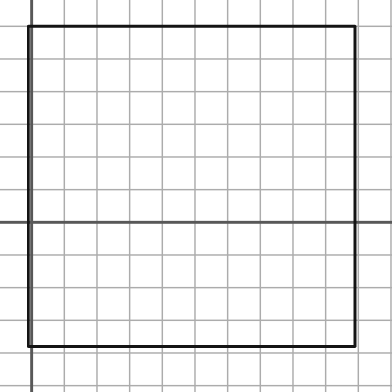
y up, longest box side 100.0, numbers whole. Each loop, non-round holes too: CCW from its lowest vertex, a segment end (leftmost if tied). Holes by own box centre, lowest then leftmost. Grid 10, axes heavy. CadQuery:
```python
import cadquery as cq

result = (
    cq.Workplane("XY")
    .moveTo(-1.0, -38.0)
    .lineTo(99.0, -38.0)
    .lineTo(99.0, 60.0)
    .lineTo(-1.0, 60.0)
    .close()
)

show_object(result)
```